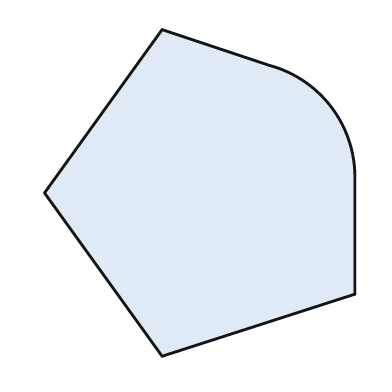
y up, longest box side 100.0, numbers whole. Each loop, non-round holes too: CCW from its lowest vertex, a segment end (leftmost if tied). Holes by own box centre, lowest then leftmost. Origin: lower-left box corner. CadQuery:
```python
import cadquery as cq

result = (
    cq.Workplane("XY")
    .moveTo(36.0, 0.0)
    .lineTo(95.0, 19.0)
    .lineTo(95.0, 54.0)
    .threePointArc((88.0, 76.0), (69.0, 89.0))
    .lineTo(36.0, 100.0)
    .lineTo(0.0, 50.0)
    .close()
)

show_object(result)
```